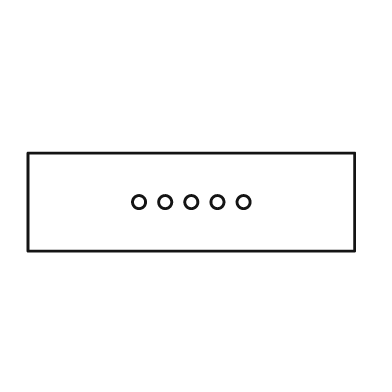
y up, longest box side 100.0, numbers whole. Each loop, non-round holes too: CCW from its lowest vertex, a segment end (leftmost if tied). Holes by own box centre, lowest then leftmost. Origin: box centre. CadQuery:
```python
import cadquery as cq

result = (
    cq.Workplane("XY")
    .moveTo(-50.0, -15.0)
    .lineTo(50.0, -15.0)
    .lineTo(50.0, 15.0)
    .lineTo(-50.0, 15.0)
    .close()
    .moveTo(-16.0, 0.0)
    .circle(2.0)
    .moveTo(-8.0, 0.0)
    .circle(2.0)
    .moveTo(0.0, 0.0)
    .circle(2.0)
    .moveTo(8.0, 0.0)
    .circle(2.0)
    .moveTo(16.0, 0.0)
    .circle(2.0)
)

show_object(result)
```